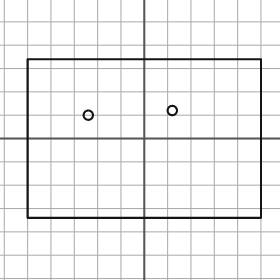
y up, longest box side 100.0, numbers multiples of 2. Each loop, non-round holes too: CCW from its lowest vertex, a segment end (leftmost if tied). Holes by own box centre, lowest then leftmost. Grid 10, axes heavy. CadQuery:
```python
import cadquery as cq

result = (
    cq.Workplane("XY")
    .moveTo(-50.0, -34.0)
    .lineTo(50.0, -34.0)
    .lineTo(50.0, 34.0)
    .lineTo(-50.0, 34.0)
    .close()
    .moveTo(-24.0, 10.0)
    .circle(2.0)
    .moveTo(12.0, 12.0)
    .circle(2.0)
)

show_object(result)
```